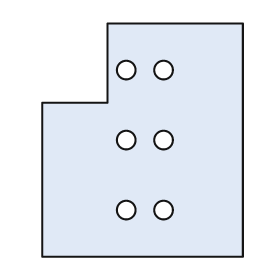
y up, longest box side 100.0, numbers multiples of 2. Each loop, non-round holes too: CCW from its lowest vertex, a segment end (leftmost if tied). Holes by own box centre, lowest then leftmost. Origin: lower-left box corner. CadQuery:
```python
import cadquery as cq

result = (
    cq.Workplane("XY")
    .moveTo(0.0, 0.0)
    .lineTo(86.0, 0.0)
    .lineTo(86.0, 100.0)
    .lineTo(28.0, 100.0)
    .lineTo(28.0, 66.0)
    .lineTo(0.0, 66.0)
    .close()
    .moveTo(36.0, 20.0)
    .circle(4.0)
    .moveTo(52.0, 20.0)
    .circle(4.0)
    .moveTo(36.0, 50.0)
    .circle(4.0)
    .moveTo(52.0, 50.0)
    .circle(4.0)
    .moveTo(36.0, 80.0)
    .circle(4.0)
    .moveTo(52.0, 80.0)
    .circle(4.0)
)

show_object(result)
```